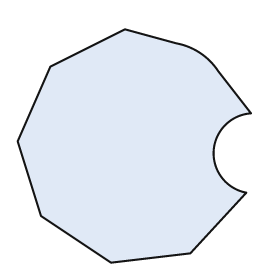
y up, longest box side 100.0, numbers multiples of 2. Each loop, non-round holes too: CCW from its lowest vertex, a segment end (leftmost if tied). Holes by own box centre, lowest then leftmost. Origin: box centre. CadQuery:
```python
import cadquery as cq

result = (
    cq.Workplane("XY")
    .moveTo(-10.0, -50.0)
    .lineTo(24.0, -46.0)
    .lineTo(48.0, -20.0)
    .threePointArc((34.0, -2.0), (50.0, 14.0))
    .lineTo(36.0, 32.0)
    .threePointArc((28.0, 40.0), (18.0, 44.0))
    .lineTo(-4.0, 50.0)
    .lineTo(-36.0, 34.0)
    .lineTo(-50.0, 2.0)
    .lineTo(-40.0, -30.0)
    .close()
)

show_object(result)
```